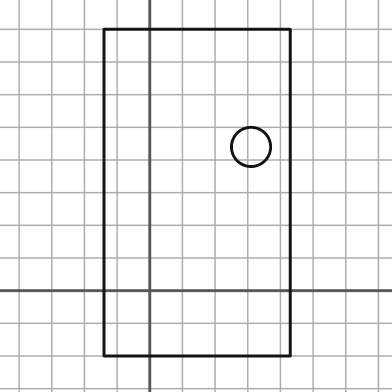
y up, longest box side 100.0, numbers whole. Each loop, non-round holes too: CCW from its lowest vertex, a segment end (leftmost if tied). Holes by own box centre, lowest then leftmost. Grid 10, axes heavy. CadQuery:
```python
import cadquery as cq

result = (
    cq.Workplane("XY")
    .moveTo(-14.0, -20.0)
    .lineTo(43.0, -20.0)
    .lineTo(43.0, 80.0)
    .lineTo(-14.0, 80.0)
    .close()
    .moveTo(31.0, 44.0)
    .circle(6.0)
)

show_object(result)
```